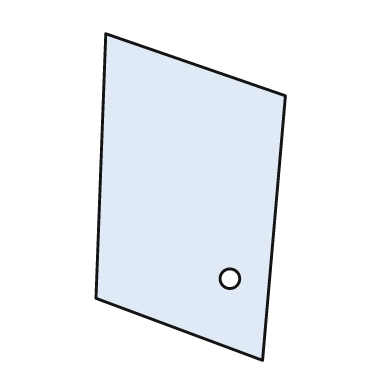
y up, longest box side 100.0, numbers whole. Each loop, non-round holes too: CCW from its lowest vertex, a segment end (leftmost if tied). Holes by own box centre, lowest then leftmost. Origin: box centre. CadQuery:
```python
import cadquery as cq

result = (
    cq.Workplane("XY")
    .moveTo(22.0, -50.0)
    .lineTo(29.0, 31.0)
    .lineTo(-26.0, 50.0)
    .lineTo(-29.0, -31.0)
    .close()
    .moveTo(12.0, -25.0)
    .circle(3.0)
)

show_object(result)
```